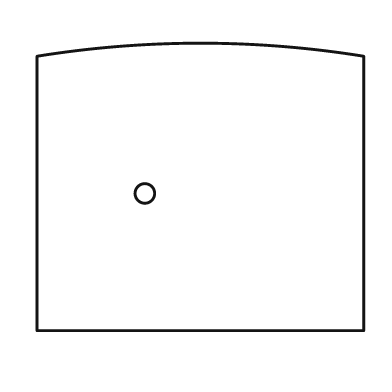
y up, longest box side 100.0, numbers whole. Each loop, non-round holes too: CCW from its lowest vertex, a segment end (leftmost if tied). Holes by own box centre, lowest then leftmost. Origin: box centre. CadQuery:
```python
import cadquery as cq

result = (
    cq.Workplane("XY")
    .moveTo(-50.0, -44.0)
    .lineTo(50.0, -44.0)
    .lineTo(50.0, 40.0)
    .threePointArc((0.0, 44.0), (-50.0, 40.0))
    .close()
    .moveTo(-17.0, -2.0)
    .circle(3.0)
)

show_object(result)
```